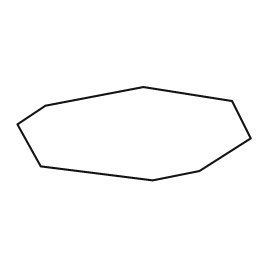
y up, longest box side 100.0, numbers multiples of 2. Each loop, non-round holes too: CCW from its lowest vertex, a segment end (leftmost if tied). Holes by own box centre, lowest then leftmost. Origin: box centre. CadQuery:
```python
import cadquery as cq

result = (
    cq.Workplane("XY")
    .moveTo(8.0, -20.0)
    .lineTo(28.0, -16.0)
    .lineTo(50.0, -2.0)
    .lineTo(42.0, 14.0)
    .lineTo(4.0, 20.0)
    .lineTo(-38.0, 12.0)
    .lineTo(-50.0, 4.0)
    .lineTo(-40.0, -14.0)
    .close()
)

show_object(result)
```